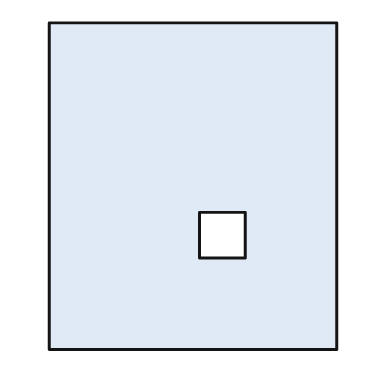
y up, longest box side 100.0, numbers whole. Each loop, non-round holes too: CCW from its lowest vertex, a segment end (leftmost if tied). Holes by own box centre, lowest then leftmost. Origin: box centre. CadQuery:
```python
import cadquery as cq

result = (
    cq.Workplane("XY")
    .moveTo(-44.0, -50.0)
    .lineTo(44.0, -50.0)
    .lineTo(44.0, 50.0)
    .lineTo(-44.0, 50.0)
    .close()
    .moveTo(2.0, -22.0)
    .lineTo(16.0, -22.0)
    .lineTo(16.0, -8.0)
    .lineTo(2.0, -8.0)
    .close()
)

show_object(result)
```